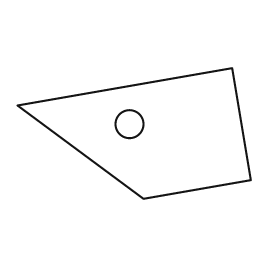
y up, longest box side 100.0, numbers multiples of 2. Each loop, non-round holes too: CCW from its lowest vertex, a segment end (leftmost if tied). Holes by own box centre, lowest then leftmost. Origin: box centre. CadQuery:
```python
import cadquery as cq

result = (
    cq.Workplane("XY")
    .moveTo(4.0, -28.0)
    .lineTo(50.0, -20.0)
    .lineTo(42.0, 28.0)
    .lineTo(-50.0, 12.0)
    .close()
    .moveTo(-2.0, 4.0)
    .circle(6.0)
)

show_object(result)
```